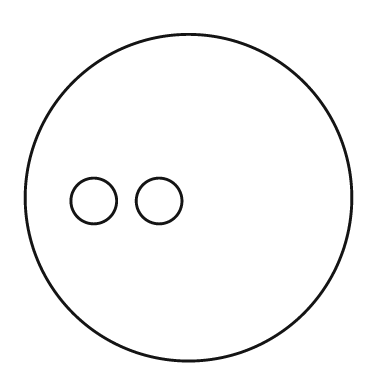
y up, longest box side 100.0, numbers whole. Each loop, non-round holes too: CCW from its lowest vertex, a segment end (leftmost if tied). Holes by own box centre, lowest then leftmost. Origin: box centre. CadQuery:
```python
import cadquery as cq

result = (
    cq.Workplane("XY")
    .moveTo(0.0, 0.0)
    .circle(50.0)
    .moveTo(-29.0, -1.0)
    .circle(7.0)
    .moveTo(-9.0, -1.0)
    .circle(7.0)
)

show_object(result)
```